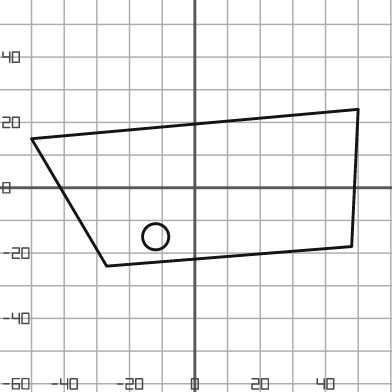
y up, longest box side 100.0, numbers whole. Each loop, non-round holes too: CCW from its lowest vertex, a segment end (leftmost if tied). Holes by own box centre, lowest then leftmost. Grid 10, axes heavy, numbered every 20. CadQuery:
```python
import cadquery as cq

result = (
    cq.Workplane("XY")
    .moveTo(-27.0, -24.0)
    .lineTo(48.0, -18.0)
    .lineTo(50.0, 24.0)
    .lineTo(-50.0, 15.0)
    .close()
    .moveTo(-12.0, -15.0)
    .circle(4.0)
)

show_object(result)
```